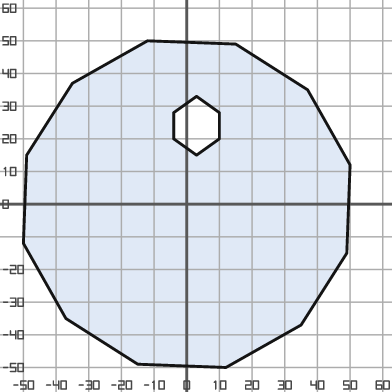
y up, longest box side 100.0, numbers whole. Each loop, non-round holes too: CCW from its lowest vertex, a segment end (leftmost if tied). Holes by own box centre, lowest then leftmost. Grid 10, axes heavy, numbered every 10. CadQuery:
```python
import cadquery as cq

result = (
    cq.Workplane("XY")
    .moveTo(12.0, -50.0)
    .lineTo(35.0, -37.0)
    .lineTo(49.0, -15.0)
    .lineTo(50.0, 12.0)
    .lineTo(37.0, 35.0)
    .lineTo(15.0, 49.0)
    .lineTo(-12.0, 50.0)
    .lineTo(-35.0, 37.0)
    .lineTo(-49.0, 15.0)
    .lineTo(-50.0, -12.0)
    .lineTo(-37.0, -35.0)
    .lineTo(-15.0, -49.0)
    .close()
    .moveTo(3.0, 15.0)
    .lineTo(10.0, 20.0)
    .lineTo(10.0, 28.0)
    .lineTo(3.0, 33.0)
    .lineTo(-4.0, 28.0)
    .lineTo(-4.0, 20.0)
    .close()
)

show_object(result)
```